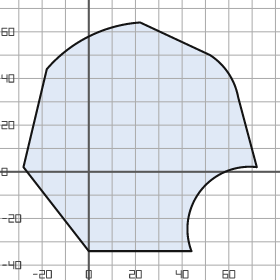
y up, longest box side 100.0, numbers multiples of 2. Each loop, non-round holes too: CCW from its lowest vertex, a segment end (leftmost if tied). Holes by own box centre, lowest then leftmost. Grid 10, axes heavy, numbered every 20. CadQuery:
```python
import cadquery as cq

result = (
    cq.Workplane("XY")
    .moveTo(0.0, -34.0)
    .lineTo(44.0, -34.0)
    .threePointArc((48.0, -8.0), (72.0, 2.0))
    .lineTo(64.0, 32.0)
    .threePointArc((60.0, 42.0), (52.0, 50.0))
    .lineTo(22.0, 64.0)
    .threePointArc((0.0, 58.0), (-18.0, 44.0))
    .lineTo(-28.0, 2.0)
    .close()
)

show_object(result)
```